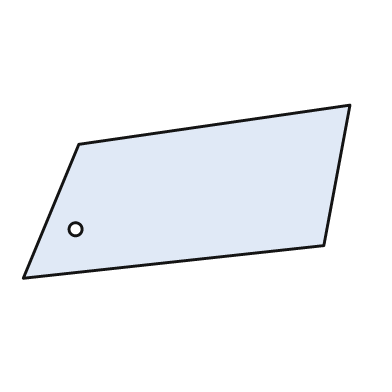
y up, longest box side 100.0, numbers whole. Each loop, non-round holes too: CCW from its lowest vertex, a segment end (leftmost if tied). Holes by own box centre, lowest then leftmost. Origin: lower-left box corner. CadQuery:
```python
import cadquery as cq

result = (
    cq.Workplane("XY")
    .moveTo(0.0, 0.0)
    .lineTo(92.0, 10.0)
    .lineTo(100.0, 53.0)
    .lineTo(17.0, 41.0)
    .close()
    .moveTo(16.0, 15.0)
    .circle(2.0)
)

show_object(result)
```